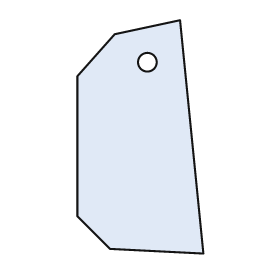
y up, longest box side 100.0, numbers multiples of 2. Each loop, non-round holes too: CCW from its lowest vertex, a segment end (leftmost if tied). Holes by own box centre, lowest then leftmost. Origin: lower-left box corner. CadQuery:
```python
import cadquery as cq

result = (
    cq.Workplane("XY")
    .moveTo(54.0, 0.0)
    .lineTo(44.0, 100.0)
    .lineTo(16.0, 94.0)
    .lineTo(0.0, 76.0)
    .lineTo(0.0, 16.0)
    .lineTo(14.0, 2.0)
    .close()
    .moveTo(30.0, 82.0)
    .circle(4.0)
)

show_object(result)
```